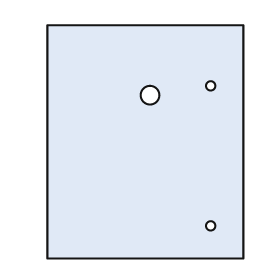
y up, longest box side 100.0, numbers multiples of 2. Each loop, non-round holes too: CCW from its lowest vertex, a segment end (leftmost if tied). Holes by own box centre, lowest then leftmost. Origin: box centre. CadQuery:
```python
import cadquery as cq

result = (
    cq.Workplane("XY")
    .moveTo(-42.0, -50.0)
    .lineTo(42.0, -50.0)
    .lineTo(42.0, 50.0)
    .lineTo(-42.0, 50.0)
    .close()
    .moveTo(28.0, -36.0)
    .circle(2.0)
    .moveTo(2.0, 20.0)
    .circle(4.0)
    .moveTo(28.0, 24.0)
    .circle(2.0)
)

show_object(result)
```